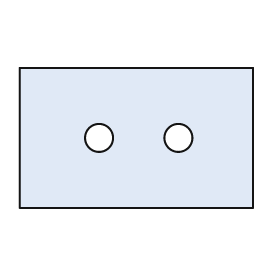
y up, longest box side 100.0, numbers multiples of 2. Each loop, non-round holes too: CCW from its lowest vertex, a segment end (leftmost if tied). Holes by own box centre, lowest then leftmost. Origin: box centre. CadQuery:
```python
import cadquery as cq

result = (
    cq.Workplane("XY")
    .moveTo(-50.0, -30.0)
    .lineTo(50.0, -30.0)
    .lineTo(50.0, 30.0)
    .lineTo(-50.0, 30.0)
    .close()
    .moveTo(-16.0, 0.0)
    .circle(6.0)
    .moveTo(18.0, 0.0)
    .circle(6.0)
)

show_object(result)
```